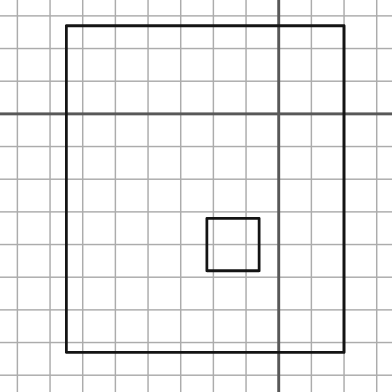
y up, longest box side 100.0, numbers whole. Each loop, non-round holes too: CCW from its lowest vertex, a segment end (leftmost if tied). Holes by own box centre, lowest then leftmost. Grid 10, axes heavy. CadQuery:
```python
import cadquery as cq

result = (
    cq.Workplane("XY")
    .moveTo(-65.0, -73.0)
    .lineTo(20.0, -73.0)
    .lineTo(20.0, 27.0)
    .lineTo(-65.0, 27.0)
    .close()
    .moveTo(-22.0, -48.0)
    .lineTo(-6.0, -48.0)
    .lineTo(-6.0, -32.0)
    .lineTo(-22.0, -32.0)
    .close()
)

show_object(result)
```